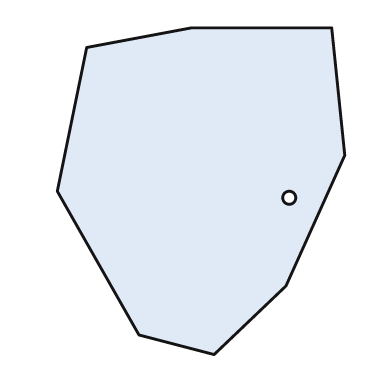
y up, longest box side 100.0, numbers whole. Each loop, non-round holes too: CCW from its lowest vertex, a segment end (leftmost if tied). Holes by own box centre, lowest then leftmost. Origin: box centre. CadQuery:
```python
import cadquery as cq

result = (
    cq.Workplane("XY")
    .moveTo(4.0, -50.0)
    .lineTo(26.0, -29.0)
    .lineTo(44.0, 11.0)
    .lineTo(40.0, 50.0)
    .lineTo(-3.0, 50.0)
    .lineTo(-35.0, 44.0)
    .lineTo(-44.0, 0.0)
    .lineTo(-19.0, -44.0)
    .close()
    .moveTo(27.0, -2.0)
    .circle(2.0)
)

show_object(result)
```